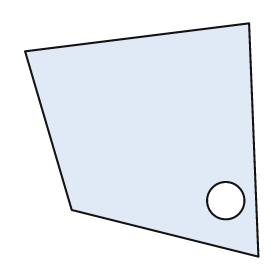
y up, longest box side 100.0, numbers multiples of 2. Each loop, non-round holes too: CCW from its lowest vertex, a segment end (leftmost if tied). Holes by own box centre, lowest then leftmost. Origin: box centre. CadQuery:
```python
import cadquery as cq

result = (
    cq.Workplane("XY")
    .moveTo(50.0, -50.0)
    .lineTo(46.0, 50.0)
    .lineTo(-50.0, 38.0)
    .lineTo(-30.0, -30.0)
    .close()
    .moveTo(36.0, -26.0)
    .circle(8.0)
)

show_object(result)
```